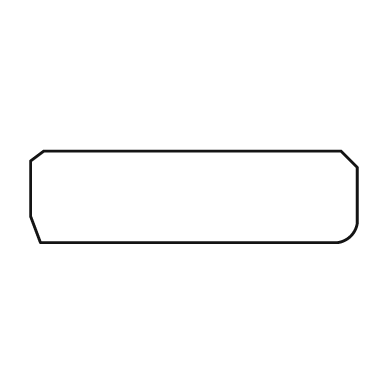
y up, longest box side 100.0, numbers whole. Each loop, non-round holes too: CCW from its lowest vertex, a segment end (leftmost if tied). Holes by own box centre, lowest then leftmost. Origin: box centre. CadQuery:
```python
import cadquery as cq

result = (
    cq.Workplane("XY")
    .moveTo(-47.0, -14.0)
    .lineTo(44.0, -14.0)
    .threePointArc((48.0, -12.0), (50.0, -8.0))
    .lineTo(50.0, 9.0)
    .lineTo(45.0, 14.0)
    .lineTo(-46.0, 14.0)
    .lineTo(-50.0, 11.0)
    .lineTo(-50.0, -6.0)
    .close()
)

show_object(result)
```